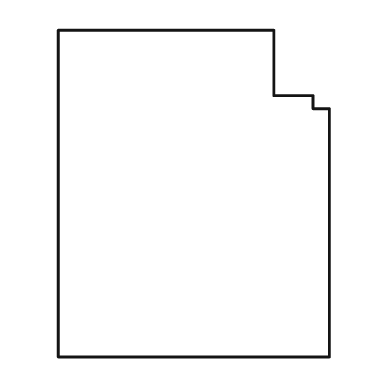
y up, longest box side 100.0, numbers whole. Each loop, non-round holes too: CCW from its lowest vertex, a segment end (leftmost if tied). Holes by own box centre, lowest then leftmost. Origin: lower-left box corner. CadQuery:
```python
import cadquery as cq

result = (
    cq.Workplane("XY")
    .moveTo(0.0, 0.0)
    .lineTo(83.0, 0.0)
    .lineTo(83.0, 76.0)
    .lineTo(78.0, 76.0)
    .lineTo(78.0, 80.0)
    .lineTo(66.0, 80.0)
    .lineTo(66.0, 100.0)
    .lineTo(0.0, 100.0)
    .close()
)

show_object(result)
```